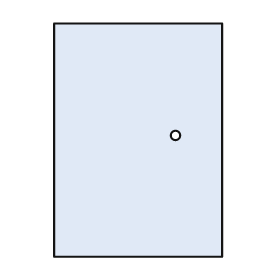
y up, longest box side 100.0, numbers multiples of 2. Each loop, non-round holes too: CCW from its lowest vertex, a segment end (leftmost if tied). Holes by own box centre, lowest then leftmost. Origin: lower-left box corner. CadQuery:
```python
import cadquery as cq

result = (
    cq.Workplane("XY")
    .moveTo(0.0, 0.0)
    .lineTo(72.0, 0.0)
    .lineTo(72.0, 100.0)
    .lineTo(0.0, 100.0)
    .close()
    .moveTo(52.0, 52.0)
    .circle(2.0)
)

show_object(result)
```